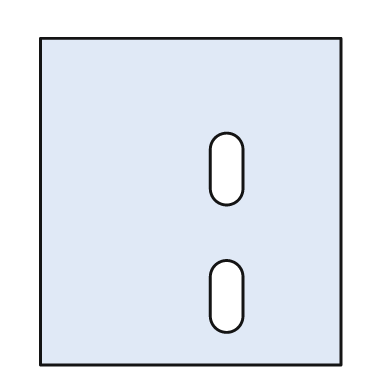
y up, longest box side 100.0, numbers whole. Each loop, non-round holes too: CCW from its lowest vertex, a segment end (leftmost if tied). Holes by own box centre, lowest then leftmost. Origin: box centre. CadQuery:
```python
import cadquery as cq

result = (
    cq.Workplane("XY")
    .moveTo(-46.0, -50.0)
    .lineTo(46.0, -50.0)
    .lineTo(46.0, 50.0)
    .lineTo(-46.0, 50.0)
    .close()
    .moveTo(6.0, -35.0)
    .threePointArc((11.0, -40.0), (16.0, -35.0))
    .lineTo(16.0, -23.0)
    .threePointArc((11.0, -18.0), (6.0, -23.0))
    .close()
    .moveTo(6.0, 4.0)
    .threePointArc((11.0, -1.0), (16.0, 4.0))
    .lineTo(16.0, 16.0)
    .threePointArc((11.0, 21.0), (6.0, 16.0))
    .close()
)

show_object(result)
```